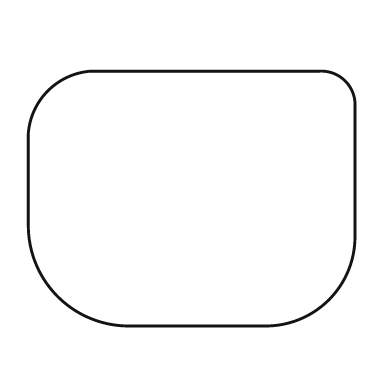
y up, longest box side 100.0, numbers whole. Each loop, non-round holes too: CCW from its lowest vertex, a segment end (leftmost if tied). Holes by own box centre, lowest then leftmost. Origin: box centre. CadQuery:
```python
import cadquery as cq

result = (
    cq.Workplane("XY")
    .moveTo(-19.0, -39.0)
    .lineTo(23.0, -39.0)
    .threePointArc((42.0, -31.0), (50.0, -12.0))
    .lineTo(50.0, 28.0)
    .threePointArc((47.0, 36.0), (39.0, 39.0))
    .lineTo(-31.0, 39.0)
    .threePointArc((-44.0, 33.0), (-50.0, 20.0))
    .lineTo(-50.0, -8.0)
    .threePointArc((-41.0, -30.0), (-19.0, -39.0))
    .close()
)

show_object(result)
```